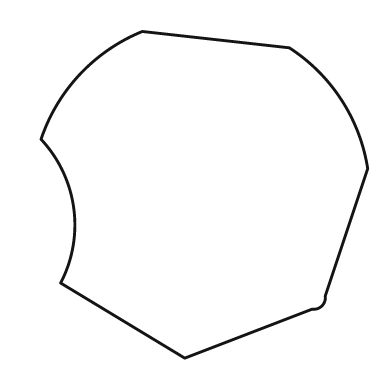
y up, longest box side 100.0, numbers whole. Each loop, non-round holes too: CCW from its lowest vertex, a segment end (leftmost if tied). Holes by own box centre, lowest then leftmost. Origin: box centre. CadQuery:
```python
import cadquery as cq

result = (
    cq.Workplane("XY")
    .moveTo(-6.0, -50.0)
    .lineTo(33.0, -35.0)
    .threePointArc((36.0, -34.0), (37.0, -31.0))
    .lineTo(50.0, 8.0)
    .threePointArc((42.0, 29.0), (26.0, 45.0))
    .lineTo(-19.0, 50.0)
    .threePointArc((-38.0, 37.0), (-50.0, 17.0))
    .threePointArc((-40.0, -4.0), (-44.0, -27.0))
    .close()
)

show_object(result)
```